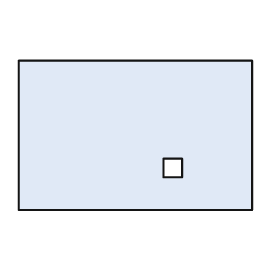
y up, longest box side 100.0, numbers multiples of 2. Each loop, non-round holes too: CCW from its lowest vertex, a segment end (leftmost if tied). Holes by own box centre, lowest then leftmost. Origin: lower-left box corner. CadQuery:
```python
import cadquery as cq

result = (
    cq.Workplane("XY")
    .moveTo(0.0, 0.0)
    .lineTo(100.0, 0.0)
    .lineTo(100.0, 64.0)
    .lineTo(0.0, 64.0)
    .close()
    .moveTo(62.0, 14.0)
    .lineTo(70.0, 14.0)
    .lineTo(70.0, 22.0)
    .lineTo(62.0, 22.0)
    .close()
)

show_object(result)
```